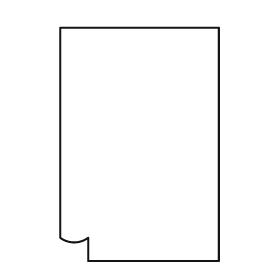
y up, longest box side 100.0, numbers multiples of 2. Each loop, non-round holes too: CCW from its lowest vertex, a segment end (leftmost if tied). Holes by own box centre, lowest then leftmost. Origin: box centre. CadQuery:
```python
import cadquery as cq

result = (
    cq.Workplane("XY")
    .moveTo(-22.0, -50.0)
    .lineTo(34.0, -50.0)
    .lineTo(34.0, 50.0)
    .lineTo(-34.0, 50.0)
    .lineTo(-34.0, -40.0)
    .threePointArc((-28.0, -42.0), (-22.0, -40.0))
    .close()
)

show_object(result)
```